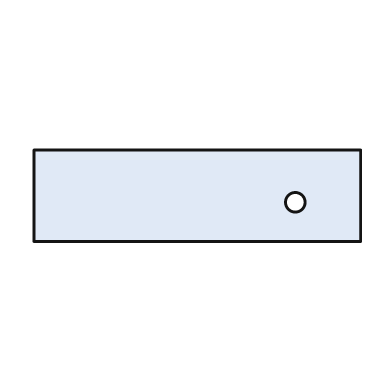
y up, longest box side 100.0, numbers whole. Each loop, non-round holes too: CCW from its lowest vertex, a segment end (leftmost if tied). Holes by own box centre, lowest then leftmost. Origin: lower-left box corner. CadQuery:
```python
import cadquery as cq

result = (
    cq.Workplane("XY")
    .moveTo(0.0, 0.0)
    .lineTo(100.0, 0.0)
    .lineTo(100.0, 28.0)
    .lineTo(0.0, 28.0)
    .close()
    .moveTo(80.0, 12.0)
    .circle(3.0)
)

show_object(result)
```